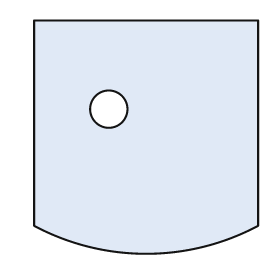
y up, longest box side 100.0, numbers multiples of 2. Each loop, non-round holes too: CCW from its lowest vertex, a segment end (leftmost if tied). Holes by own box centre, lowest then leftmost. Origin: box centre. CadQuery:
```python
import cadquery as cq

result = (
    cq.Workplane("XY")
    .moveTo(-48.0, -38.0)
    .threePointArc((0.0, -50.0), (48.0, -38.0))
    .lineTo(48.0, 50.0)
    .lineTo(-48.0, 50.0)
    .close()
    .moveTo(-16.0, 12.0)
    .circle(8.0)
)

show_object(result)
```